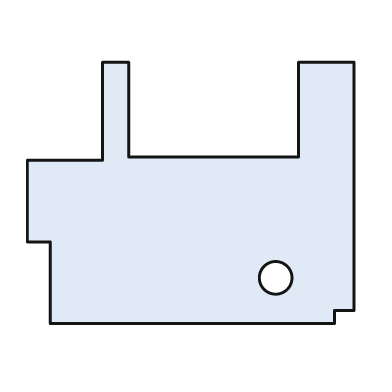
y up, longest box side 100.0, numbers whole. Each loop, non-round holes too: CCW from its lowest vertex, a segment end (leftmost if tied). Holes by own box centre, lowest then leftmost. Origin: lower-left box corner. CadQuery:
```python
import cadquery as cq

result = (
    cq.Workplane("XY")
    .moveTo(7.0, 0.0)
    .lineTo(94.0, 0.0)
    .lineTo(94.0, 4.0)
    .lineTo(100.0, 4.0)
    .lineTo(100.0, 80.0)
    .lineTo(83.0, 80.0)
    .lineTo(83.0, 51.0)
    .lineTo(31.0, 51.0)
    .lineTo(31.0, 80.0)
    .lineTo(23.0, 80.0)
    .lineTo(23.0, 50.0)
    .lineTo(0.0, 50.0)
    .lineTo(0.0, 25.0)
    .lineTo(7.0, 25.0)
    .close()
    .moveTo(76.0, 14.0)
    .circle(5.0)
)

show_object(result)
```